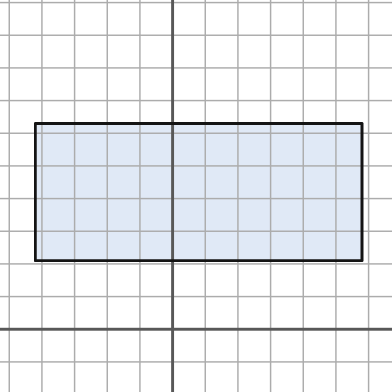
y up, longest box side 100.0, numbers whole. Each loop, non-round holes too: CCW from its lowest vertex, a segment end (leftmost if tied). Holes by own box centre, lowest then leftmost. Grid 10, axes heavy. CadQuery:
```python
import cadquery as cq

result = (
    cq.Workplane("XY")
    .moveTo(-42.0, 21.0)
    .lineTo(58.0, 21.0)
    .lineTo(58.0, 63.0)
    .lineTo(-42.0, 63.0)
    .close()
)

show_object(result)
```